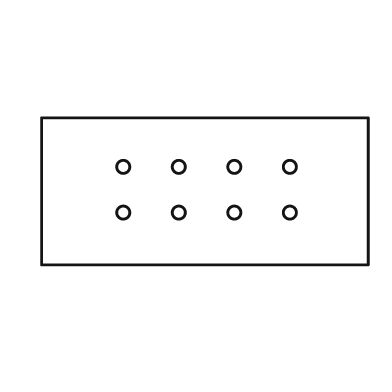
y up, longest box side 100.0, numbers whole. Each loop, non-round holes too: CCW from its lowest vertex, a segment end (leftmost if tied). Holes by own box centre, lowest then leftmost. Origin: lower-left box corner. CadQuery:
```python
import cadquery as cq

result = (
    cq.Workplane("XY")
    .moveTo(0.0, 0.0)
    .lineTo(100.0, 0.0)
    .lineTo(100.0, 45.0)
    .lineTo(0.0, 45.0)
    .close()
    .moveTo(25.0, 16.0)
    .circle(2.0)
    .moveTo(42.0, 16.0)
    .circle(2.0)
    .moveTo(59.0, 16.0)
    .circle(2.0)
    .moveTo(76.0, 16.0)
    .circle(2.0)
    .moveTo(25.0, 30.0)
    .circle(2.0)
    .moveTo(42.0, 30.0)
    .circle(2.0)
    .moveTo(59.0, 30.0)
    .circle(2.0)
    .moveTo(76.0, 30.0)
    .circle(2.0)
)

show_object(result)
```